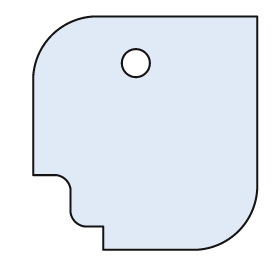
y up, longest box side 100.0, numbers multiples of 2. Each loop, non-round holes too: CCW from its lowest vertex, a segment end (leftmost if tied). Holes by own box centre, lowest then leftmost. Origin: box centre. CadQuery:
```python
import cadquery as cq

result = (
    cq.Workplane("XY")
    .moveTo(-18.0, -50.0)
    .lineTo(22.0, -50.0)
    .threePointArc((40.0, -42.0), (48.0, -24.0))
    .lineTo(48.0, 50.0)
    .lineTo(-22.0, 50.0)
    .threePointArc((-40.0, 42.0), (-48.0, 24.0))
    .lineTo(-48.0, -18.0)
    .lineTo(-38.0, -18.0)
    .threePointArc((-34.0, -20.0), (-32.0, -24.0))
    .lineTo(-32.0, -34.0)
    .threePointArc((-30.0, -38.0), (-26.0, -40.0))
    .lineTo(-18.0, -40.0)
    .close()
    .moveTo(-4.0, 30.0)
    .circle(6.0)
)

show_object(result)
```